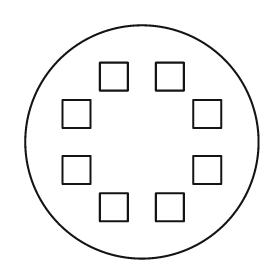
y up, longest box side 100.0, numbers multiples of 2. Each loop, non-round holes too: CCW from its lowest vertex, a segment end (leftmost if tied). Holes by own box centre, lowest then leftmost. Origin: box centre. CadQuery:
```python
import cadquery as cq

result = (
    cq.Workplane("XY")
    .moveTo(0.0, 0.0)
    .circle(50.0)
    .moveTo(-18.0, -34.0)
    .lineTo(-6.0, -34.0)
    .lineTo(-6.0, -22.0)
    .lineTo(-18.0, -22.0)
    .close()
    .moveTo(6.0, -34.0)
    .lineTo(18.0, -34.0)
    .lineTo(18.0, -22.0)
    .lineTo(6.0, -22.0)
    .close()
    .moveTo(-34.0, -18.0)
    .lineTo(-22.0, -18.0)
    .lineTo(-22.0, -6.0)
    .lineTo(-34.0, -6.0)
    .close()
    .moveTo(22.0, -18.0)
    .lineTo(34.0, -18.0)
    .lineTo(34.0, -6.0)
    .lineTo(22.0, -6.0)
    .close()
    .moveTo(-34.0, 6.0)
    .lineTo(-22.0, 6.0)
    .lineTo(-22.0, 18.0)
    .lineTo(-34.0, 18.0)
    .close()
    .moveTo(22.0, 6.0)
    .lineTo(34.0, 6.0)
    .lineTo(34.0, 18.0)
    .lineTo(22.0, 18.0)
    .close()
    .moveTo(-18.0, 22.0)
    .lineTo(-6.0, 22.0)
    .lineTo(-6.0, 34.0)
    .lineTo(-18.0, 34.0)
    .close()
    .moveTo(6.0, 22.0)
    .lineTo(18.0, 22.0)
    .lineTo(18.0, 34.0)
    .lineTo(6.0, 34.0)
    .close()
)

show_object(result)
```